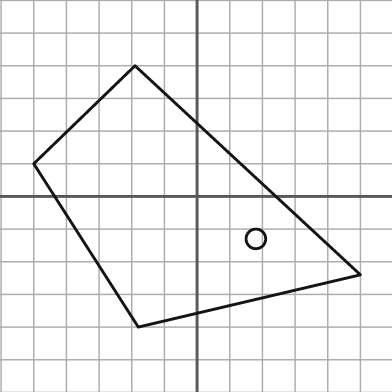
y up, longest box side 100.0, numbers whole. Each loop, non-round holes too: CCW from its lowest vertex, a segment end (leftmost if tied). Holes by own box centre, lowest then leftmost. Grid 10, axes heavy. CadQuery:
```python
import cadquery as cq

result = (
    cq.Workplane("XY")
    .moveTo(-18.0, -40.0)
    .lineTo(50.0, -24.0)
    .lineTo(-19.0, 40.0)
    .lineTo(-50.0, 10.0)
    .close()
    .moveTo(18.0, -13.0)
    .circle(3.0)
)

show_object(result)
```